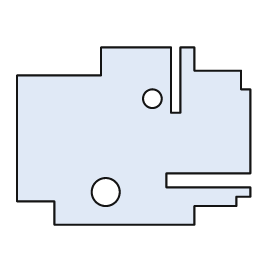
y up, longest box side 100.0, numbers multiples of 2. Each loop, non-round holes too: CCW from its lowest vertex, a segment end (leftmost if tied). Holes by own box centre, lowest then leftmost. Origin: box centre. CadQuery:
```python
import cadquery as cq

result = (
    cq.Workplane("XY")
    .moveTo(-34.0, -38.0)
    .lineTo(26.0, -38.0)
    .lineTo(26.0, -30.0)
    .lineTo(44.0, -30.0)
    .lineTo(44.0, -26.0)
    .lineTo(50.0, -26.0)
    .lineTo(50.0, -22.0)
    .lineTo(14.0, -22.0)
    .lineTo(14.0, -16.0)
    .lineTo(50.0, -16.0)
    .lineTo(50.0, 20.0)
    .lineTo(46.0, 20.0)
    .lineTo(46.0, 28.0)
    .lineTo(26.0, 28.0)
    .lineTo(26.0, 38.0)
    .lineTo(20.0, 38.0)
    .lineTo(20.0, 10.0)
    .lineTo(16.0, 10.0)
    .lineTo(16.0, 38.0)
    .lineTo(-14.0, 38.0)
    .lineTo(-14.0, 26.0)
    .lineTo(-50.0, 26.0)
    .lineTo(-50.0, -28.0)
    .lineTo(-34.0, -28.0)
    .close()
    .moveTo(-12.0, -24.0)
    .circle(6.0)
    .moveTo(8.0, 16.0)
    .circle(4.0)
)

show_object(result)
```